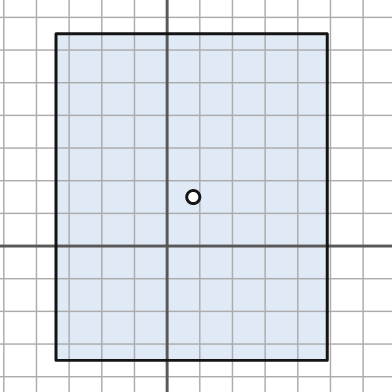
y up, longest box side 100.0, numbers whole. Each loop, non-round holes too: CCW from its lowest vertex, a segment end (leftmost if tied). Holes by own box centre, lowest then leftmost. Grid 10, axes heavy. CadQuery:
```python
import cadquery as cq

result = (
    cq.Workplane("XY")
    .moveTo(-34.0, -35.0)
    .lineTo(49.0, -35.0)
    .lineTo(49.0, 65.0)
    .lineTo(-34.0, 65.0)
    .close()
    .moveTo(8.0, 15.0)
    .circle(2.0)
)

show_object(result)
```